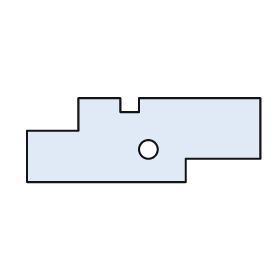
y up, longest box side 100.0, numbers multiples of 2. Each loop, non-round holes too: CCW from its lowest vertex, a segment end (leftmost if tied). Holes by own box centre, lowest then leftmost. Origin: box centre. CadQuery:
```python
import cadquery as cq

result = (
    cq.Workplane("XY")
    .moveTo(-50.0, -18.0)
    .lineTo(18.0, -18.0)
    .lineTo(18.0, -8.0)
    .lineTo(50.0, -8.0)
    .lineTo(50.0, 18.0)
    .lineTo(-2.0, 18.0)
    .lineTo(-2.0, 12.0)
    .lineTo(-10.0, 12.0)
    .lineTo(-10.0, 18.0)
    .lineTo(-28.0, 18.0)
    .lineTo(-28.0, 4.0)
    .lineTo(-50.0, 4.0)
    .close()
    .moveTo(2.0, -4.0)
    .circle(4.0)
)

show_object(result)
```